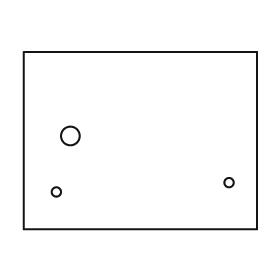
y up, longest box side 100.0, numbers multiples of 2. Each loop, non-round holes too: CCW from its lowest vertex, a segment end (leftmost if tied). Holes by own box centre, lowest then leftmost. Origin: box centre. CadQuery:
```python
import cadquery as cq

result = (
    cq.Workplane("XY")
    .moveTo(-50.0, -38.0)
    .lineTo(50.0, -38.0)
    .lineTo(50.0, 38.0)
    .lineTo(-50.0, 38.0)
    .close()
    .moveTo(-36.0, -22.0)
    .circle(2.0)
    .moveTo(38.0, -18.0)
    .circle(2.0)
    .moveTo(-30.0, 2.0)
    .circle(4.0)
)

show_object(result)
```